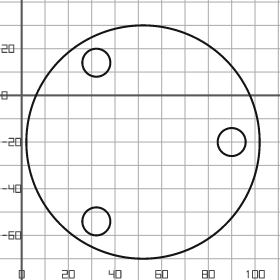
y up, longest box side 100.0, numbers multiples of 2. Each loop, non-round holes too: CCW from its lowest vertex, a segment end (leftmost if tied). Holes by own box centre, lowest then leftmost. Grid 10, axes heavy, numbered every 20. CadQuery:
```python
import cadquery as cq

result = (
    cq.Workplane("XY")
    .moveTo(52.0, -20.0)
    .circle(50.0)
    .moveTo(32.0, -54.0)
    .circle(6.0)
    .moveTo(90.0, -20.0)
    .circle(6.0)
    .moveTo(32.0, 14.0)
    .circle(6.0)
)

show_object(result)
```